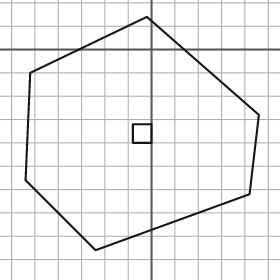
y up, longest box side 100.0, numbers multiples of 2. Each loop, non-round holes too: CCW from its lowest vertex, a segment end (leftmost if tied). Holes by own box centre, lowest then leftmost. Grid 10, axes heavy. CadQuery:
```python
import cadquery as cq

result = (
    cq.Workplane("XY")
    .moveTo(-24.0, -86.0)
    .lineTo(42.0, -62.0)
    .lineTo(46.0, -28.0)
    .lineTo(-2.0, 14.0)
    .lineTo(-52.0, -10.0)
    .lineTo(-54.0, -56.0)
    .close()
    .moveTo(-8.0, -40.0)
    .lineTo(0.0, -40.0)
    .lineTo(0.0, -32.0)
    .lineTo(-8.0, -32.0)
    .close()
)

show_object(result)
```